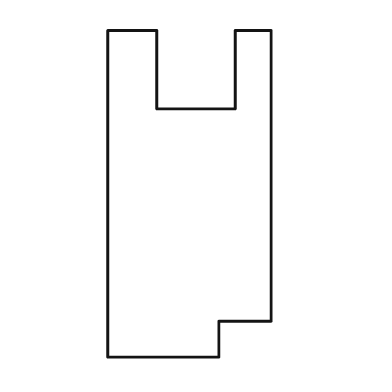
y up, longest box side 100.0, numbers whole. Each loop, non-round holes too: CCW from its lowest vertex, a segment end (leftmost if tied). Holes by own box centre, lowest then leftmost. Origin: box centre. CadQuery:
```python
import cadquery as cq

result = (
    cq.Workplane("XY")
    .moveTo(-25.0, -50.0)
    .lineTo(9.0, -50.0)
    .lineTo(9.0, -39.0)
    .lineTo(25.0, -39.0)
    .lineTo(25.0, 50.0)
    .lineTo(14.0, 50.0)
    .lineTo(14.0, 26.0)
    .lineTo(-10.0, 26.0)
    .lineTo(-10.0, 50.0)
    .lineTo(-25.0, 50.0)
    .close()
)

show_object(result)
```